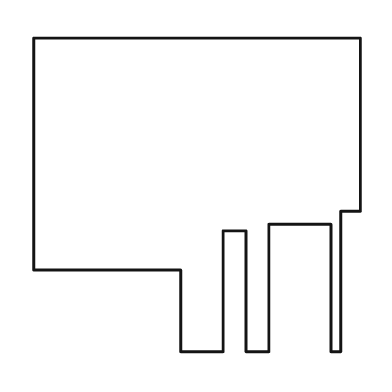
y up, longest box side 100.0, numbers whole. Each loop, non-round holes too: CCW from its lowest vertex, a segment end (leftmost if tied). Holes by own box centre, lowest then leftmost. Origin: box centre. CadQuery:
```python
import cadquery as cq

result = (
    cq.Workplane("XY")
    .moveTo(-5.0, -48.0)
    .lineTo(8.0, -48.0)
    .lineTo(8.0, -11.0)
    .lineTo(15.0, -11.0)
    .lineTo(15.0, -48.0)
    .lineTo(22.0, -48.0)
    .lineTo(22.0, -9.0)
    .lineTo(41.0, -9.0)
    .lineTo(41.0, -48.0)
    .lineTo(44.0, -48.0)
    .lineTo(44.0, -5.0)
    .lineTo(50.0, -5.0)
    .lineTo(50.0, 48.0)
    .lineTo(-50.0, 48.0)
    .lineTo(-50.0, -23.0)
    .lineTo(-5.0, -23.0)
    .close()
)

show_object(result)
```